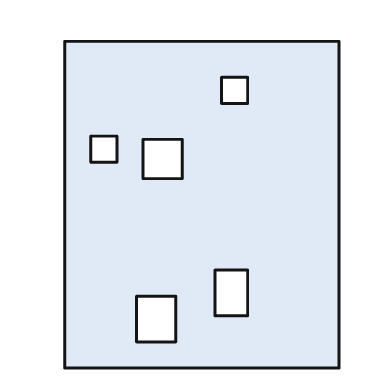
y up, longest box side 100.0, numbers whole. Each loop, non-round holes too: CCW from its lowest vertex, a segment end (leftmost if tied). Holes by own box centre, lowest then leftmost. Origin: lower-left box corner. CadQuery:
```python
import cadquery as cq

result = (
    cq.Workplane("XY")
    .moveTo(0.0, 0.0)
    .lineTo(84.0, 0.0)
    .lineTo(84.0, 100.0)
    .lineTo(0.0, 100.0)
    .close()
    .moveTo(22.0, 8.0)
    .lineTo(34.0, 8.0)
    .lineTo(34.0, 22.0)
    .lineTo(22.0, 22.0)
    .close()
    .moveTo(46.0, 16.0)
    .lineTo(56.0, 16.0)
    .lineTo(56.0, 30.0)
    .lineTo(46.0, 30.0)
    .close()
    .moveTo(24.0, 58.0)
    .lineTo(36.0, 58.0)
    .lineTo(36.0, 70.0)
    .lineTo(24.0, 70.0)
    .close()
    .moveTo(8.0, 63.0)
    .lineTo(16.0, 63.0)
    .lineTo(16.0, 71.0)
    .lineTo(8.0, 71.0)
    .close()
    .moveTo(48.0, 81.0)
    .lineTo(56.0, 81.0)
    .lineTo(56.0, 89.0)
    .lineTo(48.0, 89.0)
    .close()
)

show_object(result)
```